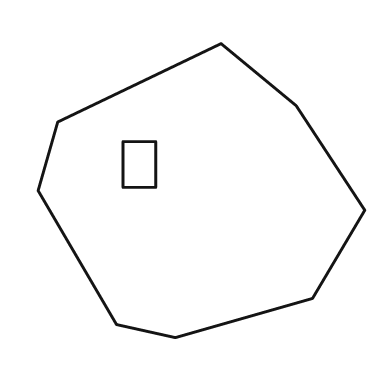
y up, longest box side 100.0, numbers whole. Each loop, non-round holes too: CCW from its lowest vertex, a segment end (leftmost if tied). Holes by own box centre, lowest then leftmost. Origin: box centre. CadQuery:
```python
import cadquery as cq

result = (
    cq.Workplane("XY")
    .moveTo(-8.0, -45.0)
    .lineTo(34.0, -33.0)
    .lineTo(50.0, -6.0)
    .lineTo(29.0, 26.0)
    .lineTo(6.0, 45.0)
    .lineTo(-44.0, 21.0)
    .lineTo(-50.0, 0.0)
    .lineTo(-26.0, -41.0)
    .close()
    .moveTo(-24.0, 1.0)
    .lineTo(-14.0, 1.0)
    .lineTo(-14.0, 15.0)
    .lineTo(-24.0, 15.0)
    .close()
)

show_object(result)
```